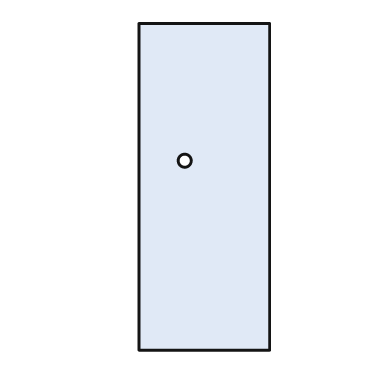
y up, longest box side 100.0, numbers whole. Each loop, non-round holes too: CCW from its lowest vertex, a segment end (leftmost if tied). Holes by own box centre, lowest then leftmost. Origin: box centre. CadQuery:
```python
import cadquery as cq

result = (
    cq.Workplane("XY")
    .moveTo(-20.0, -50.0)
    .lineTo(20.0, -50.0)
    .lineTo(20.0, 50.0)
    .lineTo(-20.0, 50.0)
    .close()
    .moveTo(-6.0, 8.0)
    .circle(2.0)
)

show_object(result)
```